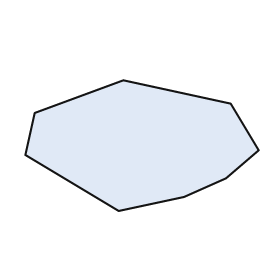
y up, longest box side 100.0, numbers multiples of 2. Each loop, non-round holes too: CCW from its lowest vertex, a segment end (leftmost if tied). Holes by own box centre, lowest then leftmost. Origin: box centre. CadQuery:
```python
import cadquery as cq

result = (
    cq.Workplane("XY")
    .moveTo(-10.0, -28.0)
    .lineTo(18.0, -22.0)
    .lineTo(36.0, -14.0)
    .lineTo(50.0, -2.0)
    .lineTo(38.0, 18.0)
    .lineTo(-8.0, 28.0)
    .lineTo(-46.0, 14.0)
    .lineTo(-50.0, -4.0)
    .close()
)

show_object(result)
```